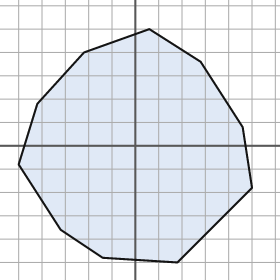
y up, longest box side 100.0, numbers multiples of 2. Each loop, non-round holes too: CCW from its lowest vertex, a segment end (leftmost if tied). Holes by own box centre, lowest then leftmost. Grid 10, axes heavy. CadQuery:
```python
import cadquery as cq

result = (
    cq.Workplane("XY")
    .moveTo(18.0, -50.0)
    .lineTo(50.0, -18.0)
    .lineTo(46.0, 8.0)
    .lineTo(28.0, 36.0)
    .lineTo(6.0, 50.0)
    .lineTo(-22.0, 40.0)
    .lineTo(-42.0, 18.0)
    .lineTo(-50.0, -8.0)
    .lineTo(-32.0, -36.0)
    .lineTo(-14.0, -48.0)
    .close()
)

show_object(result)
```